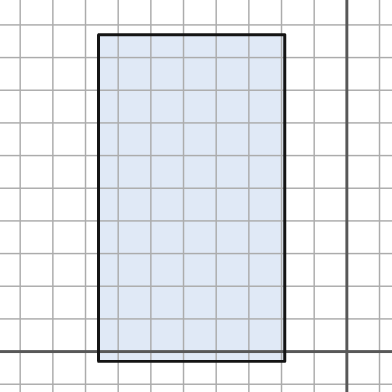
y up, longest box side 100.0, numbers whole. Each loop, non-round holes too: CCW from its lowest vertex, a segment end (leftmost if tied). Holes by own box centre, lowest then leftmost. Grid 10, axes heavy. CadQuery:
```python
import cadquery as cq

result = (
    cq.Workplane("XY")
    .moveTo(-76.0, -3.0)
    .lineTo(-19.0, -3.0)
    .lineTo(-19.0, 97.0)
    .lineTo(-76.0, 97.0)
    .close()
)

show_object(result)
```